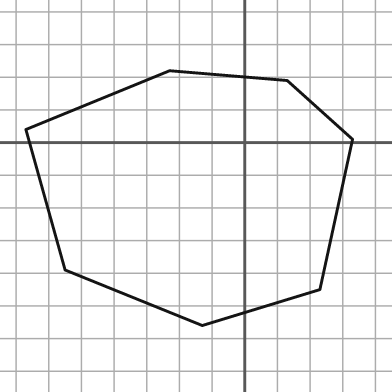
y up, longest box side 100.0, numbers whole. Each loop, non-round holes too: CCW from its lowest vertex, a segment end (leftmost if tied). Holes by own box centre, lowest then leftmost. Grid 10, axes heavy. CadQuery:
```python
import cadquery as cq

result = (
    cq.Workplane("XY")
    .moveTo(-13.0, -56.0)
    .lineTo(23.0, -45.0)
    .lineTo(33.0, 1.0)
    .lineTo(13.0, 19.0)
    .lineTo(-23.0, 22.0)
    .lineTo(-67.0, 4.0)
    .lineTo(-55.0, -39.0)
    .close()
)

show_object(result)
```